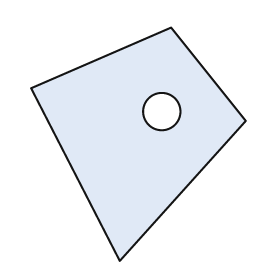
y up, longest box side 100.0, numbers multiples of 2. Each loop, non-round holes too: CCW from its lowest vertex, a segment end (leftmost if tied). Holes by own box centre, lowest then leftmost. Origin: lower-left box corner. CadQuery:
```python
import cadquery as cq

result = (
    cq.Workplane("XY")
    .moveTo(38.0, 0.0)
    .lineTo(92.0, 60.0)
    .lineTo(60.0, 100.0)
    .lineTo(0.0, 74.0)
    .close()
    .moveTo(56.0, 64.0)
    .circle(8.0)
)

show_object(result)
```